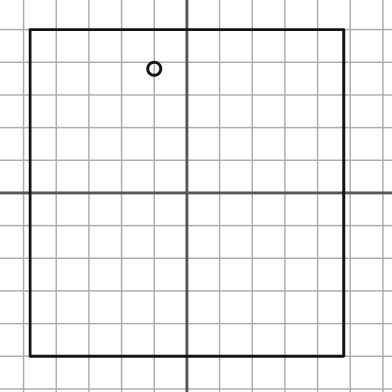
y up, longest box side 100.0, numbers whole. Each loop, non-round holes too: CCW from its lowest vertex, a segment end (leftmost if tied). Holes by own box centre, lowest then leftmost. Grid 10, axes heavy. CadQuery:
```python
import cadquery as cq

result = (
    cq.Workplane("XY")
    .moveTo(-48.0, -50.0)
    .lineTo(48.0, -50.0)
    .lineTo(48.0, 50.0)
    .lineTo(-48.0, 50.0)
    .close()
    .moveTo(-10.0, 38.0)
    .circle(2.0)
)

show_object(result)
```